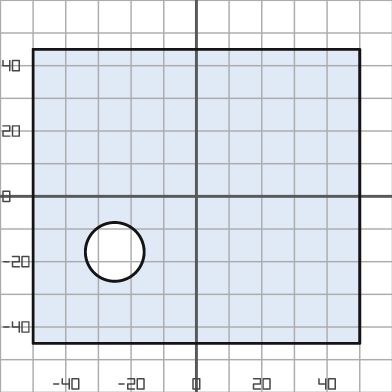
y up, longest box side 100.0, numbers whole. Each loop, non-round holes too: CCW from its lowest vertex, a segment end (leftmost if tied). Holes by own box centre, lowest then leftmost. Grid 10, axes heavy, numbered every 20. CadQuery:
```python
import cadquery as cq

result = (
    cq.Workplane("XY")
    .moveTo(-50.0, -45.0)
    .lineTo(50.0, -45.0)
    .lineTo(50.0, 45.0)
    .lineTo(-50.0, 45.0)
    .close()
    .moveTo(-25.0, -17.0)
    .circle(9.0)
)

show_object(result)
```